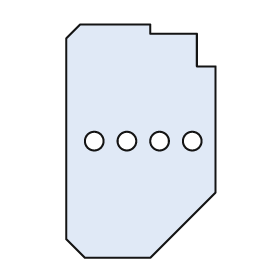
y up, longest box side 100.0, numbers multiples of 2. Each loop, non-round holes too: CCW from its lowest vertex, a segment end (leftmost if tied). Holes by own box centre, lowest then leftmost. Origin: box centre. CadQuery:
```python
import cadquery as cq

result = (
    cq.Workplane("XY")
    .moveTo(-24.0, -50.0)
    .lineTo(4.0, -50.0)
    .lineTo(32.0, -22.0)
    .lineTo(32.0, 32.0)
    .lineTo(24.0, 32.0)
    .lineTo(24.0, 46.0)
    .lineTo(4.0, 46.0)
    .lineTo(4.0, 50.0)
    .lineTo(-26.0, 50.0)
    .lineTo(-32.0, 44.0)
    .lineTo(-32.0, -42.0)
    .close()
    .moveTo(-20.0, 0.0)
    .circle(4.0)
    .moveTo(-6.0, 0.0)
    .circle(4.0)
    .moveTo(8.0, 0.0)
    .circle(4.0)
    .moveTo(22.0, 0.0)
    .circle(4.0)
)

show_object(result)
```